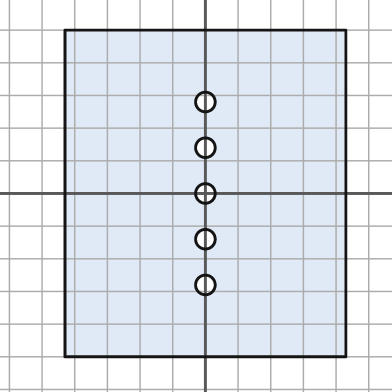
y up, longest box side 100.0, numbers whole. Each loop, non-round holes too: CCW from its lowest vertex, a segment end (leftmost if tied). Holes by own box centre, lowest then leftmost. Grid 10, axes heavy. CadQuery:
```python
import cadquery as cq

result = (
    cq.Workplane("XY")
    .moveTo(-43.0, -50.0)
    .lineTo(43.0, -50.0)
    .lineTo(43.0, 50.0)
    .lineTo(-43.0, 50.0)
    .close()
    .moveTo(0.0, -28.0)
    .circle(3.0)
    .moveTo(0.0, -14.0)
    .circle(3.0)
    .moveTo(0.0, 0.0)
    .circle(3.0)
    .moveTo(0.0, 14.0)
    .circle(3.0)
    .moveTo(0.0, 28.0)
    .circle(3.0)
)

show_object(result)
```